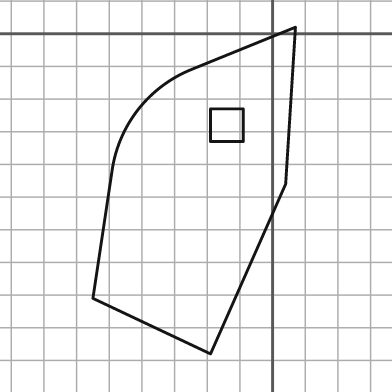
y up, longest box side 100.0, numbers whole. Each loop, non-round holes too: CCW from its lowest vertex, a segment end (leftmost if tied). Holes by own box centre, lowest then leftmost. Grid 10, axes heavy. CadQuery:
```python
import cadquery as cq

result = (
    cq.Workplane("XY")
    .moveTo(-19.0, -98.0)
    .lineTo(4.0, -46.0)
    .lineTo(7.0, 2.0)
    .lineTo(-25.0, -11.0)
    .threePointArc((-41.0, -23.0), (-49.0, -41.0))
    .lineTo(-55.0, -81.0)
    .close()
    .moveTo(-19.0, -33.0)
    .lineTo(-9.0, -33.0)
    .lineTo(-9.0, -23.0)
    .lineTo(-19.0, -23.0)
    .close()
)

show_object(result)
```